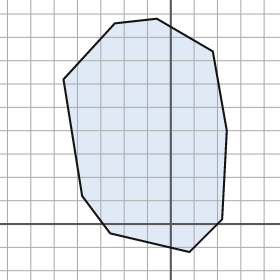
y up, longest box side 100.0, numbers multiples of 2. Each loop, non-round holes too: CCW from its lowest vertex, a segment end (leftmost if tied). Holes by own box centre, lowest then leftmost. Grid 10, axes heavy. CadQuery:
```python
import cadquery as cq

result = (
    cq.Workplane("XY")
    .moveTo(8.0, -12.0)
    .lineTo(22.0, 2.0)
    .lineTo(24.0, 40.0)
    .lineTo(18.0, 74.0)
    .lineTo(-6.0, 88.0)
    .lineTo(-24.0, 86.0)
    .lineTo(-46.0, 62.0)
    .lineTo(-38.0, 12.0)
    .lineTo(-26.0, -4.0)
    .close()
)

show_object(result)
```